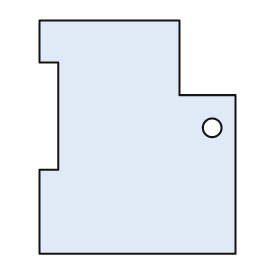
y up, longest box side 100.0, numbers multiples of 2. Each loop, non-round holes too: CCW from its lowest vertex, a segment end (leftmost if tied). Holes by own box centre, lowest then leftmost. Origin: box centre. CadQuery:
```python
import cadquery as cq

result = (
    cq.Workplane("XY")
    .moveTo(-42.0, -50.0)
    .lineTo(42.0, -50.0)
    .lineTo(42.0, 18.0)
    .lineTo(18.0, 18.0)
    .lineTo(18.0, 50.0)
    .lineTo(-42.0, 50.0)
    .lineTo(-42.0, 32.0)
    .lineTo(-34.0, 32.0)
    .lineTo(-34.0, -14.0)
    .lineTo(-42.0, -14.0)
    .close()
    .moveTo(32.0, 4.0)
    .circle(4.0)
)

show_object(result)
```